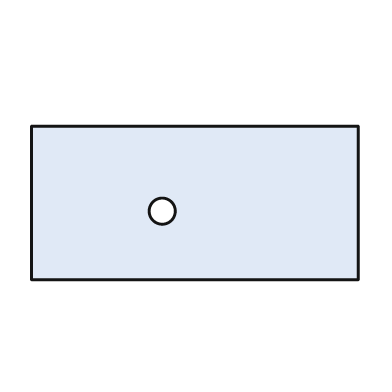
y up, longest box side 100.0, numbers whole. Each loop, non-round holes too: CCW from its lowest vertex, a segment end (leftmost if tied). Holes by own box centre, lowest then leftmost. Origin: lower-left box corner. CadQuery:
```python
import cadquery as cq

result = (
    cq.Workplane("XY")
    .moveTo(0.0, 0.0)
    .lineTo(100.0, 0.0)
    .lineTo(100.0, 47.0)
    .lineTo(0.0, 47.0)
    .close()
    .moveTo(40.0, 21.0)
    .circle(4.0)
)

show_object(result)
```